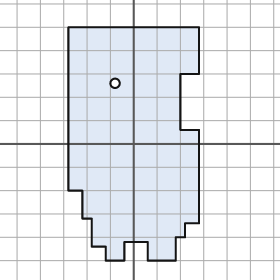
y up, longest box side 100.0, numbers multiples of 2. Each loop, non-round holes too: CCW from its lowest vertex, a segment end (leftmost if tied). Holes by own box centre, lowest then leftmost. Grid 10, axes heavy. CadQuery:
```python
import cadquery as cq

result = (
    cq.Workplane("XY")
    .moveTo(-12.0, -50.0)
    .lineTo(-4.0, -50.0)
    .lineTo(-4.0, -42.0)
    .lineTo(6.0, -42.0)
    .lineTo(6.0, -50.0)
    .lineTo(18.0, -50.0)
    .lineTo(18.0, -40.0)
    .lineTo(22.0, -40.0)
    .lineTo(22.0, -34.0)
    .lineTo(28.0, -34.0)
    .lineTo(28.0, 6.0)
    .lineTo(20.0, 6.0)
    .lineTo(20.0, 30.0)
    .lineTo(28.0, 30.0)
    .lineTo(28.0, 50.0)
    .lineTo(-28.0, 50.0)
    .lineTo(-28.0, -20.0)
    .lineTo(-22.0, -20.0)
    .lineTo(-22.0, -32.0)
    .lineTo(-18.0, -32.0)
    .lineTo(-18.0, -44.0)
    .lineTo(-12.0, -44.0)
    .close()
    .moveTo(-8.0, 26.0)
    .circle(2.0)
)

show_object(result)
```